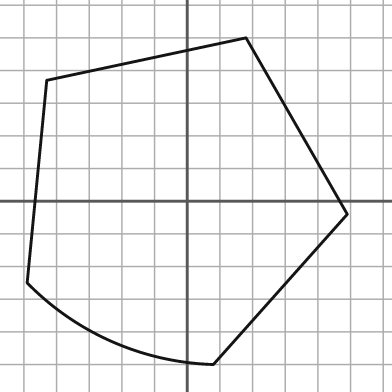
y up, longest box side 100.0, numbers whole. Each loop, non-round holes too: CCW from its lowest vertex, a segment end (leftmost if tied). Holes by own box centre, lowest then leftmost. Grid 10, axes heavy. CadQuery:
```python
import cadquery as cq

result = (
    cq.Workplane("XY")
    .moveTo(8.0, -50.0)
    .lineTo(49.0, -4.0)
    .lineTo(18.0, 50.0)
    .lineTo(-43.0, 37.0)
    .lineTo(-49.0, -25.0)
    .threePointArc((-23.0, -43.0), (8.0, -50.0))
    .close()
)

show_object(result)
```